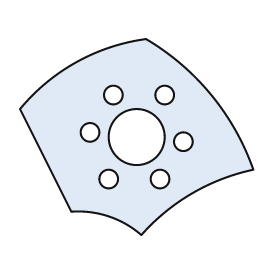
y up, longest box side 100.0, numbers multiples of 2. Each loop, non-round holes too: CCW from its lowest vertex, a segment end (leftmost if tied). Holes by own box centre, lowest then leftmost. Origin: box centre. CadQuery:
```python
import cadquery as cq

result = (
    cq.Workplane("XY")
    .moveTo(2.0, -42.0)
    .threePointArc((24.0, -24.0), (50.0, -14.0))
    .threePointArc((32.0, 18.0), (4.0, 42.0))
    .threePointArc((-26.0, 32.0), (-50.0, 12.0))
    .lineTo(-28.0, -32.0)
    .threePointArc((-12.0, -34.0), (2.0, -42.0))
    .close()
    .moveTo(-12.0, -18.0)
    .circle(4.0)
    .moveTo(10.0, -18.0)
    .circle(4.0)
    .moveTo(20.0, -2.0)
    .circle(4.0)
    .moveTo(0.0, 0.0)
    .circle(12.0)
    .moveTo(-20.0, 2.0)
    .circle(4.0)
    .moveTo(-10.0, 18.0)
    .circle(4.0)
    .moveTo(12.0, 18.0)
    .circle(4.0)
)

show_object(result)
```